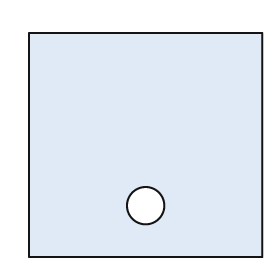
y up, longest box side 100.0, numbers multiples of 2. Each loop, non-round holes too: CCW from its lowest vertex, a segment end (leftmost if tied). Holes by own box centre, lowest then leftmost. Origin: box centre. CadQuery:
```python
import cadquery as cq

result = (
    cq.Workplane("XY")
    .moveTo(-50.0, -48.0)
    .lineTo(50.0, -48.0)
    .lineTo(50.0, 48.0)
    .lineTo(-50.0, 48.0)
    .close()
    .moveTo(0.0, -26.0)
    .circle(8.0)
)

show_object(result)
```